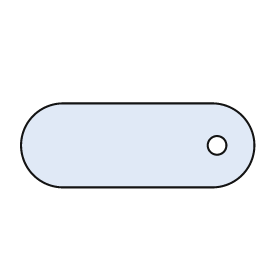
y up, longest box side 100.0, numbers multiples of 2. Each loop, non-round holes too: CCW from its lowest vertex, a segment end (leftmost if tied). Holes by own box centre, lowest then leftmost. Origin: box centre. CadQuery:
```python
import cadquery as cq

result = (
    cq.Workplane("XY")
    .moveTo(-32.0, -18.0)
    .lineTo(32.0, -18.0)
    .threePointArc((50.0, 0.0), (32.0, 18.0))
    .lineTo(-32.0, 18.0)
    .threePointArc((-50.0, 0.0), (-32.0, -18.0))
    .close()
    .moveTo(34.0, 0.0)
    .circle(4.0)
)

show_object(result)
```